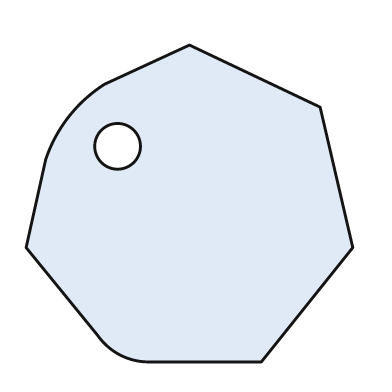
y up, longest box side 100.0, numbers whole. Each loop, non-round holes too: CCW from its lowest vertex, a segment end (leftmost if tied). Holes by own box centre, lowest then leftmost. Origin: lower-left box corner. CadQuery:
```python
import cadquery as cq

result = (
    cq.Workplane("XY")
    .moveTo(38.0, 0.0)
    .lineTo(72.0, 0.0)
    .lineTo(100.0, 35.0)
    .lineTo(90.0, 78.0)
    .lineTo(50.0, 97.0)
    .lineTo(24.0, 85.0)
    .threePointArc((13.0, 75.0), (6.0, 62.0))
    .lineTo(0.0, 35.0)
    .lineTo(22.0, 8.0)
    .threePointArc((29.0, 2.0), (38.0, 0.0))
    .close()
    .moveTo(28.0, 66.0)
    .circle(7.0)
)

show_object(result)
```